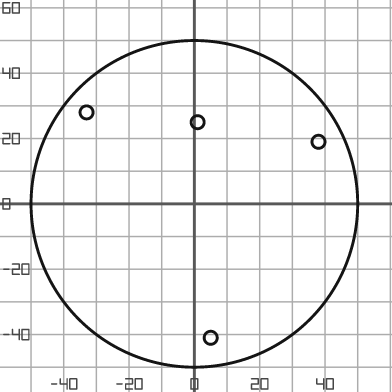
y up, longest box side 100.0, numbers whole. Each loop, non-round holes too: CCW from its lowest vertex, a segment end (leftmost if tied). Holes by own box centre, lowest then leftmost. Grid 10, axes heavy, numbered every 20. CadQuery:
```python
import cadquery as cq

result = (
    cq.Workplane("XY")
    .moveTo(0.0, 0.0)
    .circle(50.0)
    .moveTo(5.0, -41.0)
    .circle(2.0)
    .moveTo(38.0, 19.0)
    .circle(2.0)
    .moveTo(1.0, 25.0)
    .circle(2.0)
    .moveTo(-33.0, 28.0)
    .circle(2.0)
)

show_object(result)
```